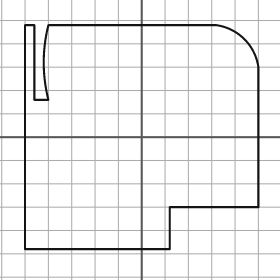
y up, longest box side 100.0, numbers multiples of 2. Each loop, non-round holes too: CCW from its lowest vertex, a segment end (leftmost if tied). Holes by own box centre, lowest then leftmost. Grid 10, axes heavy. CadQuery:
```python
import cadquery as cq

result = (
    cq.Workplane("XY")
    .moveTo(-50.0, -48.0)
    .lineTo(12.0, -48.0)
    .lineTo(12.0, -30.0)
    .lineTo(50.0, -30.0)
    .lineTo(50.0, 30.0)
    .threePointArc((44.0, 42.0), (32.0, 48.0))
    .lineTo(-40.0, 48.0)
    .threePointArc((-42.0, 32.0), (-40.0, 16.0))
    .lineTo(-46.0, 16.0)
    .lineTo(-46.0, 48.0)
    .lineTo(-50.0, 48.0)
    .close()
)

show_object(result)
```